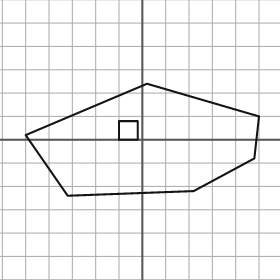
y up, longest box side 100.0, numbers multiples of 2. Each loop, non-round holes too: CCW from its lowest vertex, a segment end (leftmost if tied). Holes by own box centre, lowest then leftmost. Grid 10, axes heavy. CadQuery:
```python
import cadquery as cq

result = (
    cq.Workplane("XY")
    .moveTo(-32.0, -24.0)
    .lineTo(22.0, -22.0)
    .lineTo(48.0, -8.0)
    .lineTo(50.0, 10.0)
    .lineTo(2.0, 24.0)
    .lineTo(-50.0, 2.0)
    .close()
    .moveTo(-10.0, 0.0)
    .lineTo(-2.0, 0.0)
    .lineTo(-2.0, 8.0)
    .lineTo(-10.0, 8.0)
    .close()
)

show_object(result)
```